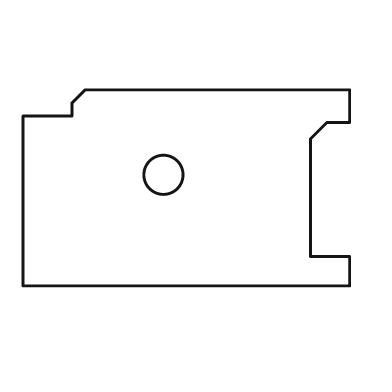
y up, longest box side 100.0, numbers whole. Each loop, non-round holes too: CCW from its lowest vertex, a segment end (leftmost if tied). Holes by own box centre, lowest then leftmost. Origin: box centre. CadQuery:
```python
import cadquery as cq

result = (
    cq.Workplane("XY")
    .moveTo(-50.0, -30.0)
    .lineTo(50.0, -30.0)
    .lineTo(50.0, -21.0)
    .lineTo(38.0, -21.0)
    .lineTo(38.0, 15.0)
    .lineTo(43.0, 20.0)
    .lineTo(50.0, 20.0)
    .lineTo(50.0, 30.0)
    .lineTo(-31.0, 30.0)
    .lineTo(-35.0, 26.0)
    .lineTo(-35.0, 22.0)
    .lineTo(-50.0, 22.0)
    .close()
    .moveTo(-7.0, 4.0)
    .circle(6.0)
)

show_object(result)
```